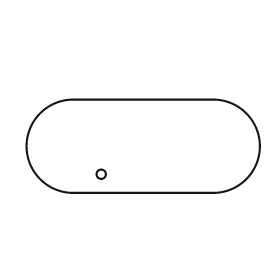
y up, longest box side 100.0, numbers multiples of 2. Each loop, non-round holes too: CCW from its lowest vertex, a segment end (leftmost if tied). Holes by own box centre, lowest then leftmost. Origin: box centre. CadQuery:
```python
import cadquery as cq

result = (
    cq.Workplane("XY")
    .moveTo(-30.0, -20.0)
    .lineTo(30.0, -20.0)
    .threePointArc((50.0, 0.0), (30.0, 20.0))
    .lineTo(-30.0, 20.0)
    .threePointArc((-50.0, 0.0), (-30.0, -20.0))
    .close()
    .moveTo(-18.0, -12.0)
    .circle(2.0)
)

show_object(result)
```